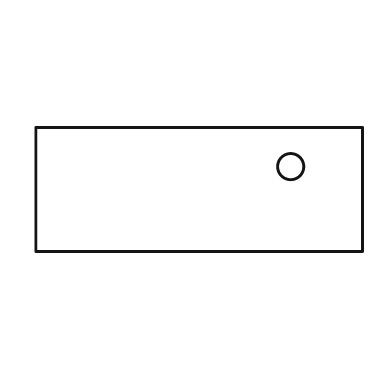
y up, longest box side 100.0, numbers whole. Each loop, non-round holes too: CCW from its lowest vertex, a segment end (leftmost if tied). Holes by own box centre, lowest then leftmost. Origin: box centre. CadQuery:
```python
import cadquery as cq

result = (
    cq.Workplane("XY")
    .moveTo(-50.0, -19.0)
    .lineTo(50.0, -19.0)
    .lineTo(50.0, 19.0)
    .lineTo(-50.0, 19.0)
    .close()
    .moveTo(28.0, 7.0)
    .circle(4.0)
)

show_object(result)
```